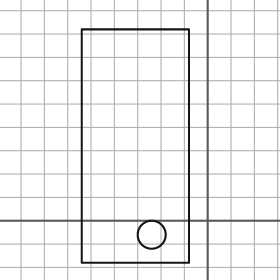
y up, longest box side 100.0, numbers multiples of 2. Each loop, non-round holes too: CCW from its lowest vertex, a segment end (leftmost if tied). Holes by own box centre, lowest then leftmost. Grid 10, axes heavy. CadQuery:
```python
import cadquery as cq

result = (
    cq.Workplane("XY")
    .moveTo(-54.0, -18.0)
    .lineTo(-8.0, -18.0)
    .lineTo(-8.0, 82.0)
    .lineTo(-54.0, 82.0)
    .close()
    .moveTo(-24.0, -6.0)
    .circle(6.0)
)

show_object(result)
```